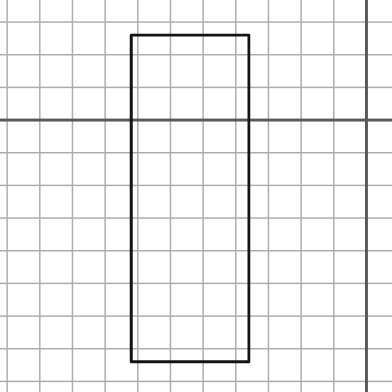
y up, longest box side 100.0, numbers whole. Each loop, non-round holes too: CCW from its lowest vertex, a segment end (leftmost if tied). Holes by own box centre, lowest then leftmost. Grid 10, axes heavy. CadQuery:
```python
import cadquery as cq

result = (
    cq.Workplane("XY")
    .moveTo(-72.0, -74.0)
    .lineTo(-36.0, -74.0)
    .lineTo(-36.0, 26.0)
    .lineTo(-72.0, 26.0)
    .close()
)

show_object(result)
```